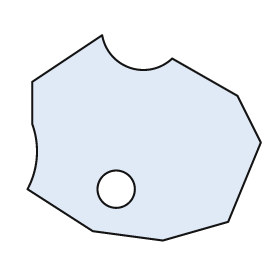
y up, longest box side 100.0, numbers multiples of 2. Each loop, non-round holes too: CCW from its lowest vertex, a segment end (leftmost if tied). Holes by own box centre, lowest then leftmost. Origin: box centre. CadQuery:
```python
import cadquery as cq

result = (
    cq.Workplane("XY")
    .moveTo(8.0, -44.0)
    .lineTo(36.0, -36.0)
    .lineTo(50.0, -2.0)
    .lineTo(40.0, 18.0)
    .lineTo(12.0, 34.0)
    .threePointArc((-6.0, 30.0), (-18.0, 44.0))
    .lineTo(-48.0, 24.0)
    .lineTo(-48.0, 6.0)
    .threePointArc((-46.0, -8.0), (-50.0, -22.0))
    .lineTo(-22.0, -40.0)
    .close()
    .moveTo(-12.0, -22.0)
    .circle(8.0)
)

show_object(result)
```